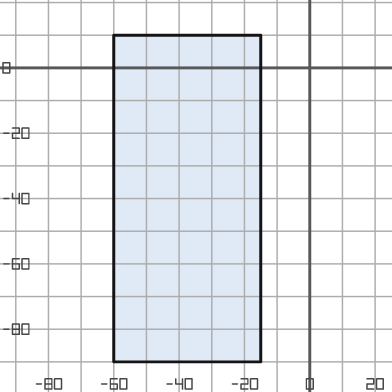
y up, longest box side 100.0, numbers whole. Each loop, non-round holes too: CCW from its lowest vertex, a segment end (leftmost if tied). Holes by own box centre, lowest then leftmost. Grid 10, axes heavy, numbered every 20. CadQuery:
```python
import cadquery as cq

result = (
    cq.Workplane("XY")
    .moveTo(-60.0, -90.0)
    .lineTo(-15.0, -90.0)
    .lineTo(-15.0, 10.0)
    .lineTo(-60.0, 10.0)
    .close()
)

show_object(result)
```